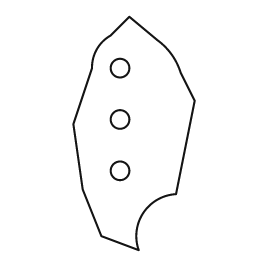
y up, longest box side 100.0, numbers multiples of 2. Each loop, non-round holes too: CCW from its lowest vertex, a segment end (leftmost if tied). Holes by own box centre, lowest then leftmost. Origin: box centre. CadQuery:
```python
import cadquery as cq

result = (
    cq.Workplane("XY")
    .moveTo(2.0, -50.0)
    .threePointArc((4.0, -34.0), (18.0, -26.0))
    .lineTo(26.0, 14.0)
    .lineTo(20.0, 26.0)
    .threePointArc((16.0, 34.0), (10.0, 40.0))
    .lineTo(-2.0, 50.0)
    .lineTo(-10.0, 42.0)
    .threePointArc((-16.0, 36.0), (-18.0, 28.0))
    .lineTo(-26.0, 4.0)
    .lineTo(-22.0, -24.0)
    .lineTo(-14.0, -44.0)
    .close()
    .moveTo(-6.0, -16.0)
    .circle(4.0)
    .moveTo(-6.0, 6.0)
    .circle(4.0)
    .moveTo(-6.0, 28.0)
    .circle(4.0)
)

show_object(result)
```